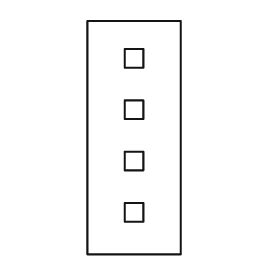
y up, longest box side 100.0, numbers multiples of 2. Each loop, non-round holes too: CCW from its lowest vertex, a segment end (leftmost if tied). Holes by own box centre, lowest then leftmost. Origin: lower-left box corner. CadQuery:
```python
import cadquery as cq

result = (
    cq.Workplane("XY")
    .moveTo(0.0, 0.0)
    .lineTo(40.0, 0.0)
    .lineTo(40.0, 100.0)
    .lineTo(0.0, 100.0)
    .close()
    .moveTo(16.0, 14.0)
    .lineTo(24.0, 14.0)
    .lineTo(24.0, 22.0)
    .lineTo(16.0, 22.0)
    .close()
    .moveTo(16.0, 36.0)
    .lineTo(24.0, 36.0)
    .lineTo(24.0, 44.0)
    .lineTo(16.0, 44.0)
    .close()
    .moveTo(16.0, 58.0)
    .lineTo(24.0, 58.0)
    .lineTo(24.0, 66.0)
    .lineTo(16.0, 66.0)
    .close()
    .moveTo(16.0, 80.0)
    .lineTo(24.0, 80.0)
    .lineTo(24.0, 88.0)
    .lineTo(16.0, 88.0)
    .close()
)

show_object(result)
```